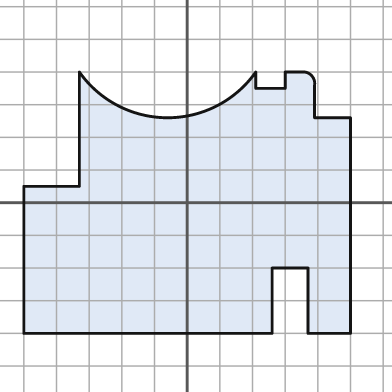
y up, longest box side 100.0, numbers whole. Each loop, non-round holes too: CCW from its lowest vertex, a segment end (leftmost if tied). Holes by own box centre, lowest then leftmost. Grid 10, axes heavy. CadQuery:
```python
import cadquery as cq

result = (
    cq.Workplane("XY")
    .moveTo(-50.0, -40.0)
    .lineTo(26.0, -40.0)
    .lineTo(26.0, -20.0)
    .lineTo(37.0, -20.0)
    .lineTo(37.0, -40.0)
    .lineTo(50.0, -40.0)
    .lineTo(50.0, 26.0)
    .lineTo(39.0, 26.0)
    .lineTo(39.0, 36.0)
    .threePointArc((38.0, 39.0), (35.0, 40.0))
    .lineTo(30.0, 40.0)
    .lineTo(30.0, 35.0)
    .lineTo(21.0, 35.0)
    .lineTo(21.0, 40.0)
    .threePointArc((-6.0, 26.0), (-33.0, 40.0))
    .lineTo(-33.0, 5.0)
    .lineTo(-50.0, 5.0)
    .close()
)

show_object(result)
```